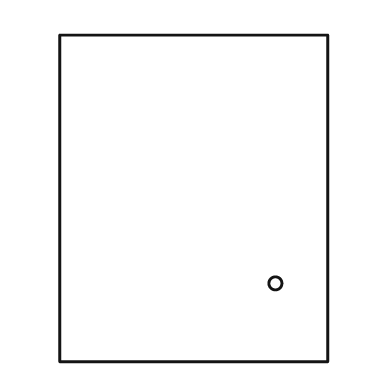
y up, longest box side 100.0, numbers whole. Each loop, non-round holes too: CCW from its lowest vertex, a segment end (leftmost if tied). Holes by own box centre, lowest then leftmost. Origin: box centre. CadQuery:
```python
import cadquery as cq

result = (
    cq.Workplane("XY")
    .moveTo(-41.0, -50.0)
    .lineTo(41.0, -50.0)
    .lineTo(41.0, 50.0)
    .lineTo(-41.0, 50.0)
    .close()
    .moveTo(25.0, -26.0)
    .circle(2.0)
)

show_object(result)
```